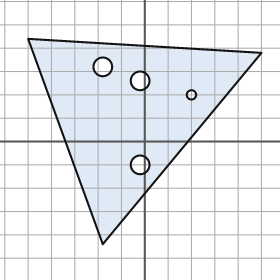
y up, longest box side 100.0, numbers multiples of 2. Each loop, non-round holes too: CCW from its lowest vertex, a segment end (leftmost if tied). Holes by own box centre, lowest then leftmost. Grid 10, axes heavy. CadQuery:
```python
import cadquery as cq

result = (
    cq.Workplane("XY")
    .moveTo(-18.0, -44.0)
    .lineTo(50.0, 38.0)
    .lineTo(-50.0, 44.0)
    .close()
    .moveTo(-2.0, -10.0)
    .circle(4.0)
    .moveTo(20.0, 20.0)
    .circle(2.0)
    .moveTo(-2.0, 26.0)
    .circle(4.0)
    .moveTo(-18.0, 32.0)
    .circle(4.0)
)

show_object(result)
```